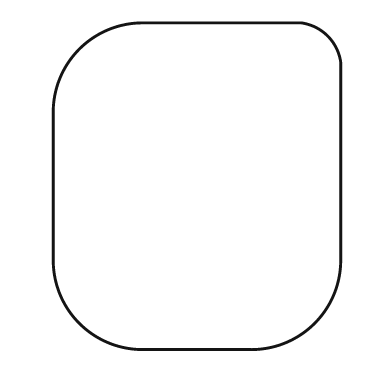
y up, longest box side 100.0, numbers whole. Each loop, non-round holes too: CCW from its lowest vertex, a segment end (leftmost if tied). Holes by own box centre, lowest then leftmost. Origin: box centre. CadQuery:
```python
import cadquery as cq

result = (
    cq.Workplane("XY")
    .moveTo(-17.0, -50.0)
    .lineTo(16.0, -50.0)
    .threePointArc((36.0, -42.0), (44.0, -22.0))
    .lineTo(44.0, 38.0)
    .threePointArc((40.0, 46.0), (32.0, 50.0))
    .lineTo(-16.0, 50.0)
    .threePointArc((-36.0, 42.0), (-44.0, 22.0))
    .lineTo(-44.0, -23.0)
    .threePointArc((-36.0, -42.0), (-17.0, -50.0))
    .close()
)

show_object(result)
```